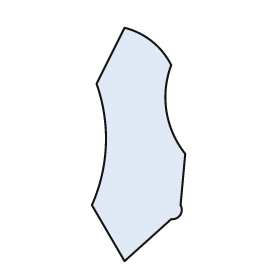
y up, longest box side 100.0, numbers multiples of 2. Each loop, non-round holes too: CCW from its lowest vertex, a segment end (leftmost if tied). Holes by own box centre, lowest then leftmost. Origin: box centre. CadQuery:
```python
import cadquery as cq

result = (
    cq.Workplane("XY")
    .moveTo(-6.0, -50.0)
    .lineTo(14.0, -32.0)
    .threePointArc((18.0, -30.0), (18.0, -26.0))
    .lineTo(20.0, -4.0)
    .threePointArc((12.0, 14.0), (14.0, 34.0))
    .threePointArc((6.0, 44.0), (-6.0, 50.0))
    .lineTo(-18.0, 26.0)
    .threePointArc((-14.0, 0.0), (-20.0, -26.0))
    .close()
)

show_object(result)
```